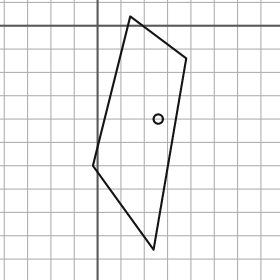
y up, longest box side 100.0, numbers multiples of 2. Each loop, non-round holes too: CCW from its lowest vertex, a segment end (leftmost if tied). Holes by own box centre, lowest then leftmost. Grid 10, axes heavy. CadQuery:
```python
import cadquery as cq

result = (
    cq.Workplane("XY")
    .moveTo(24.0, -96.0)
    .lineTo(38.0, -14.0)
    .lineTo(14.0, 4.0)
    .lineTo(-2.0, -60.0)
    .close()
    .moveTo(26.0, -40.0)
    .circle(2.0)
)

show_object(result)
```